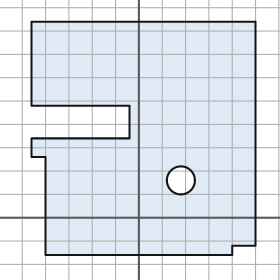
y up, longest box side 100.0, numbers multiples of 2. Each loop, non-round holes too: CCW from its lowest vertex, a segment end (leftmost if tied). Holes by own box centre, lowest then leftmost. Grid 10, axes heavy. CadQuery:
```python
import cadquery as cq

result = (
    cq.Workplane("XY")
    .moveTo(-40.0, -16.0)
    .lineTo(40.0, -16.0)
    .lineTo(40.0, -12.0)
    .lineTo(50.0, -12.0)
    .lineTo(50.0, 84.0)
    .lineTo(-46.0, 84.0)
    .lineTo(-46.0, 48.0)
    .lineTo(-4.0, 48.0)
    .lineTo(-4.0, 34.0)
    .lineTo(-46.0, 34.0)
    .lineTo(-46.0, 26.0)
    .lineTo(-40.0, 26.0)
    .close()
    .moveTo(18.0, 16.0)
    .circle(6.0)
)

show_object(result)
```